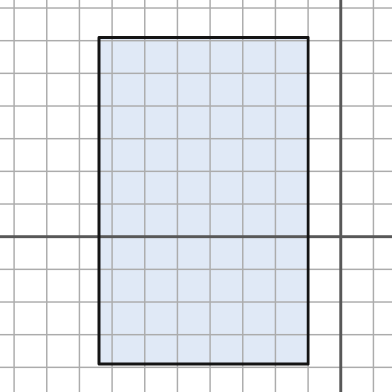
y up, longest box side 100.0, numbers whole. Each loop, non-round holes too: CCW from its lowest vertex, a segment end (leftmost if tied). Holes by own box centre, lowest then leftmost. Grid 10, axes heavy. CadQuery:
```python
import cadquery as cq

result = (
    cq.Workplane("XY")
    .moveTo(-74.0, -39.0)
    .lineTo(-10.0, -39.0)
    .lineTo(-10.0, 61.0)
    .lineTo(-74.0, 61.0)
    .close()
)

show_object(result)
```